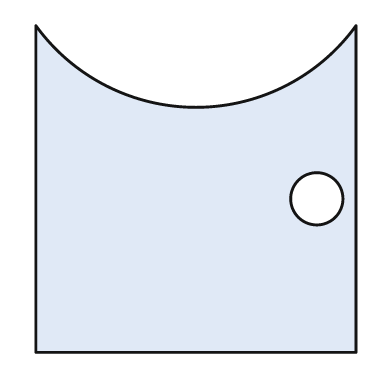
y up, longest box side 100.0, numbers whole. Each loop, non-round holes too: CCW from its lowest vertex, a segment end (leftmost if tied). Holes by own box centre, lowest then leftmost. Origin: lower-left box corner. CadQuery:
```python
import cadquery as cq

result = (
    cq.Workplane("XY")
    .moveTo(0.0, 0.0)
    .lineTo(98.0, 0.0)
    .lineTo(98.0, 100.0)
    .threePointArc((49.0, 75.0), (0.0, 100.0))
    .close()
    .moveTo(86.0, 47.0)
    .circle(8.0)
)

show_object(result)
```